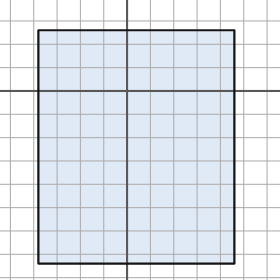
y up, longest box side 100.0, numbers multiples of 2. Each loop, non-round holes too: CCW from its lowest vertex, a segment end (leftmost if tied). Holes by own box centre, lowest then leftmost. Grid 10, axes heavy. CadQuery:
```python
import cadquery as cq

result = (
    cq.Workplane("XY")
    .moveTo(-38.0, -74.0)
    .lineTo(46.0, -74.0)
    .lineTo(46.0, 26.0)
    .lineTo(-38.0, 26.0)
    .close()
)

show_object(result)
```